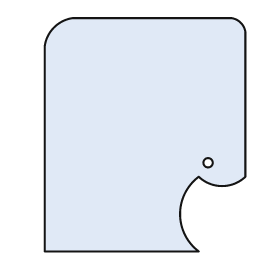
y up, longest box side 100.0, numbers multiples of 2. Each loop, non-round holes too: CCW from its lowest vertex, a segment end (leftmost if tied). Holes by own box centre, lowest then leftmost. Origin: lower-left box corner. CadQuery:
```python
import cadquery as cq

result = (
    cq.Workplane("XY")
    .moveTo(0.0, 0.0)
    .lineTo(66.0, 0.0)
    .threePointArc((58.0, 16.0), (66.0, 32.0))
    .threePointArc((76.0, 28.0), (86.0, 32.0))
    .lineTo(86.0, 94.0)
    .threePointArc((84.0, 98.0), (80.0, 100.0))
    .lineTo(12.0, 100.0)
    .threePointArc((4.0, 96.0), (0.0, 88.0))
    .close()
    .moveTo(70.0, 38.0)
    .circle(2.0)
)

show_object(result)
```